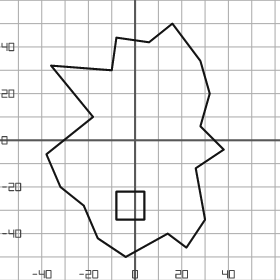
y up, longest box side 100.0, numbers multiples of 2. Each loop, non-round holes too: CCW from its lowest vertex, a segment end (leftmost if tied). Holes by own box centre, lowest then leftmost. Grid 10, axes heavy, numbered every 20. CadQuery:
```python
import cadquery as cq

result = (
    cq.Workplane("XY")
    .moveTo(-4.0, -50.0)
    .lineTo(14.0, -40.0)
    .lineTo(22.0, -46.0)
    .lineTo(30.0, -34.0)
    .lineTo(26.0, -12.0)
    .lineTo(38.0, -4.0)
    .lineTo(28.0, 6.0)
    .lineTo(32.0, 20.0)
    .lineTo(28.0, 34.0)
    .lineTo(16.0, 50.0)
    .lineTo(6.0, 42.0)
    .lineTo(-8.0, 44.0)
    .lineTo(-10.0, 30.0)
    .lineTo(-36.0, 32.0)
    .lineTo(-18.0, 10.0)
    .lineTo(-38.0, -6.0)
    .lineTo(-32.0, -20.0)
    .lineTo(-22.0, -28.0)
    .lineTo(-16.0, -42.0)
    .close()
    .moveTo(-8.0, -34.0)
    .lineTo(4.0, -34.0)
    .lineTo(4.0, -22.0)
    .lineTo(-8.0, -22.0)
    .close()
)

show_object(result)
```